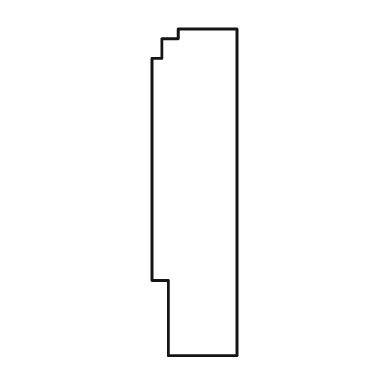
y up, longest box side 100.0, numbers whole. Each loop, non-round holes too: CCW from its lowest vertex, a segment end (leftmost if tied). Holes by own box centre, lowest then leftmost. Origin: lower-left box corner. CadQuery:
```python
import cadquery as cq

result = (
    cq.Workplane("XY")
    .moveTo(5.0, 0.0)
    .lineTo(26.0, 0.0)
    .lineTo(26.0, 100.0)
    .lineTo(8.0, 100.0)
    .lineTo(8.0, 97.0)
    .lineTo(3.0, 97.0)
    .lineTo(3.0, 91.0)
    .lineTo(0.0, 91.0)
    .lineTo(0.0, 23.0)
    .lineTo(5.0, 23.0)
    .close()
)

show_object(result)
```